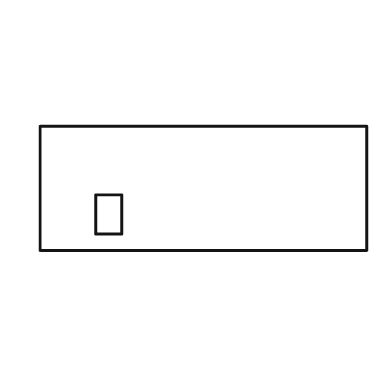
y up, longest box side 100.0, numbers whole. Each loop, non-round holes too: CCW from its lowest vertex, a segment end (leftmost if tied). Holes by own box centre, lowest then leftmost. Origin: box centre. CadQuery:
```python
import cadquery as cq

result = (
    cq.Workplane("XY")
    .moveTo(-50.0, -19.0)
    .lineTo(50.0, -19.0)
    .lineTo(50.0, 19.0)
    .lineTo(-50.0, 19.0)
    .close()
    .moveTo(-33.0, -14.0)
    .lineTo(-25.0, -14.0)
    .lineTo(-25.0, -2.0)
    .lineTo(-33.0, -2.0)
    .close()
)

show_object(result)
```